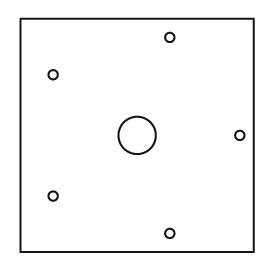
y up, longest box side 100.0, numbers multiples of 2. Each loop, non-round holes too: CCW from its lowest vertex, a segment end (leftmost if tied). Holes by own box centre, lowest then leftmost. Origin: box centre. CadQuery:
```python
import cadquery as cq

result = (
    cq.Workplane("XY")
    .moveTo(-50.0, -50.0)
    .lineTo(50.0, -50.0)
    .lineTo(50.0, 50.0)
    .lineTo(-50.0, 50.0)
    .close()
    .moveTo(14.0, -42.0)
    .circle(2.0)
    .moveTo(-36.0, -26.0)
    .circle(2.0)
    .moveTo(0.0, 0.0)
    .circle(8.0)
    .moveTo(44.0, 0.0)
    .circle(2.0)
    .moveTo(-36.0, 26.0)
    .circle(2.0)
    .moveTo(14.0, 42.0)
    .circle(2.0)
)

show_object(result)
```